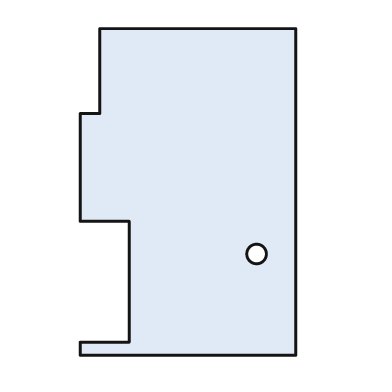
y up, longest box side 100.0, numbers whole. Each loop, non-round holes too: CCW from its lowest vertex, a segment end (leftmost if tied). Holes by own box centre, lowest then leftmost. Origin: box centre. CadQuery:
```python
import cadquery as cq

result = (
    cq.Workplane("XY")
    .moveTo(-33.0, -50.0)
    .lineTo(33.0, -50.0)
    .lineTo(33.0, 50.0)
    .lineTo(-27.0, 50.0)
    .lineTo(-27.0, 24.0)
    .lineTo(-33.0, 24.0)
    .lineTo(-33.0, -9.0)
    .lineTo(-18.0, -9.0)
    .lineTo(-18.0, -46.0)
    .lineTo(-33.0, -46.0)
    .close()
    .moveTo(21.0, -19.0)
    .circle(3.0)
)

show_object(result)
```